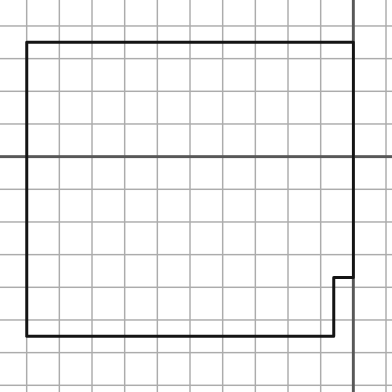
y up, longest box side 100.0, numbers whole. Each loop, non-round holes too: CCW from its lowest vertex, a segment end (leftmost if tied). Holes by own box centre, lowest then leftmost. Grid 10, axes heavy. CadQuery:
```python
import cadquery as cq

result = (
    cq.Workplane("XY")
    .moveTo(-100.0, -55.0)
    .lineTo(-6.0, -55.0)
    .lineTo(-6.0, -37.0)
    .lineTo(0.0, -37.0)
    .lineTo(0.0, 35.0)
    .lineTo(-100.0, 35.0)
    .close()
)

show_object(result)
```